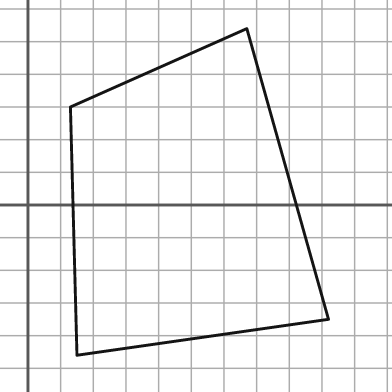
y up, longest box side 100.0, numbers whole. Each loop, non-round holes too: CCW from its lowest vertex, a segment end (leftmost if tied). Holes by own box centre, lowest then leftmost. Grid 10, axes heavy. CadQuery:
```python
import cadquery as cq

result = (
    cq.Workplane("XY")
    .moveTo(15.0, -46.0)
    .lineTo(92.0, -35.0)
    .lineTo(67.0, 54.0)
    .lineTo(13.0, 30.0)
    .close()
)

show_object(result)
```